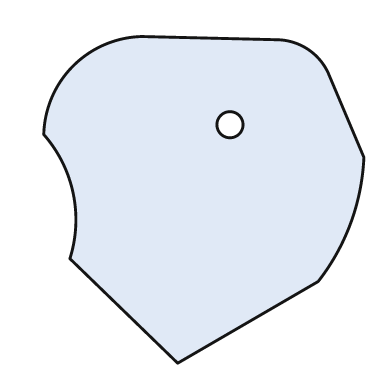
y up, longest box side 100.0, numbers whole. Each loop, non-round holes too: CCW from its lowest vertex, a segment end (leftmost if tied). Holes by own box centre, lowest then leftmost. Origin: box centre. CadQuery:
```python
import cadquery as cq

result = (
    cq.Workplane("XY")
    .moveTo(-8.0, -50.0)
    .lineTo(35.0, -25.0)
    .threePointArc((45.0, -7.0), (49.0, 13.0))
    .lineTo(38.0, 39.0)
    .threePointArc((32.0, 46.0), (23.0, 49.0))
    .lineTo(-19.0, 50.0)
    .threePointArc((-40.0, 41.0), (-49.0, 20.0))
    .threePointArc((-40.0, 2.0), (-41.0, -18.0))
    .close()
    .moveTo(8.0, 23.0)
    .circle(4.0)
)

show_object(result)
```